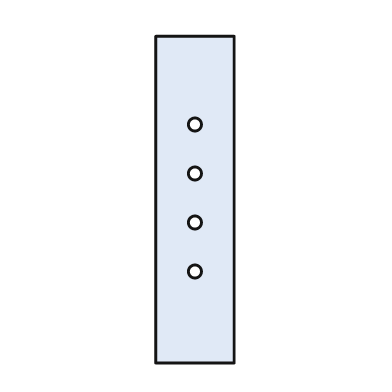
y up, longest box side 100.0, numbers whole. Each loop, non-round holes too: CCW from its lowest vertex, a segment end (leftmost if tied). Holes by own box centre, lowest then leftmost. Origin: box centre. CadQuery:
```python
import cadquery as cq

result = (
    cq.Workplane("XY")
    .moveTo(-12.0, -50.0)
    .lineTo(12.0, -50.0)
    .lineTo(12.0, 50.0)
    .lineTo(-12.0, 50.0)
    .close()
    .moveTo(0.0, -22.0)
    .circle(2.0)
    .moveTo(0.0, -7.0)
    .circle(2.0)
    .moveTo(0.0, 8.0)
    .circle(2.0)
    .moveTo(0.0, 23.0)
    .circle(2.0)
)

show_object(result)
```